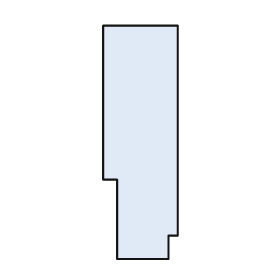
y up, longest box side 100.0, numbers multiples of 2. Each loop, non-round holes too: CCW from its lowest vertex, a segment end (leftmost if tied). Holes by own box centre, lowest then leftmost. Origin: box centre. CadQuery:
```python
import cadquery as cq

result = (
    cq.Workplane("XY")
    .moveTo(-10.0, -50.0)
    .lineTo(12.0, -50.0)
    .lineTo(12.0, -40.0)
    .lineTo(16.0, -40.0)
    .lineTo(16.0, 50.0)
    .lineTo(-16.0, 50.0)
    .lineTo(-16.0, -16.0)
    .lineTo(-10.0, -16.0)
    .close()
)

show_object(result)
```